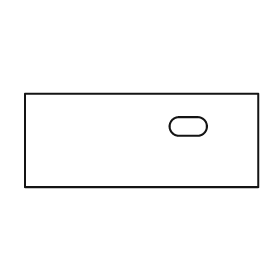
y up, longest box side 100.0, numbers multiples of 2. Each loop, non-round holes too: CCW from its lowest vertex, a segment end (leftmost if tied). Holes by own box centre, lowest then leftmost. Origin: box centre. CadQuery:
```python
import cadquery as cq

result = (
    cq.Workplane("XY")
    .moveTo(-50.0, -20.0)
    .lineTo(50.0, -20.0)
    .lineTo(50.0, 20.0)
    .lineTo(-50.0, 20.0)
    .close()
    .moveTo(16.0, 2.0)
    .lineTo(24.0, 2.0)
    .threePointArc((28.0, 6.0), (24.0, 10.0))
    .lineTo(16.0, 10.0)
    .threePointArc((12.0, 6.0), (16.0, 2.0))
    .close()
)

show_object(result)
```